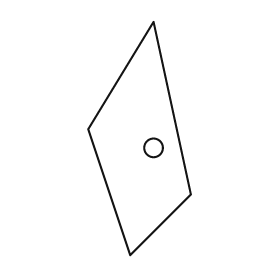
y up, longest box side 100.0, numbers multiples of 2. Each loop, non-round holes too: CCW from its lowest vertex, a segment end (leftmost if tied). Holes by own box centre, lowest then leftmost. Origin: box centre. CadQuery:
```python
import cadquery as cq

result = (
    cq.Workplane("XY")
    .moveTo(-4.0, -50.0)
    .lineTo(22.0, -24.0)
    .lineTo(6.0, 50.0)
    .lineTo(-22.0, 4.0)
    .close()
    .moveTo(6.0, -4.0)
    .circle(4.0)
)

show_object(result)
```